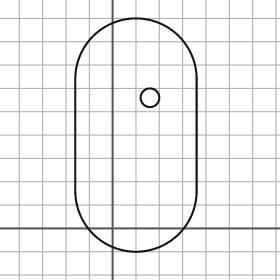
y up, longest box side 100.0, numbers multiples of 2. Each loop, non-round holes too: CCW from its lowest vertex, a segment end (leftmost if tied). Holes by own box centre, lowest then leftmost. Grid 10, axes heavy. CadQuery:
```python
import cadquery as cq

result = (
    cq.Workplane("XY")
    .moveTo(-16.0, 16.0)
    .threePointArc((10.0, -10.0), (36.0, 16.0))
    .lineTo(36.0, 64.0)
    .threePointArc((10.0, 90.0), (-16.0, 64.0))
    .close()
    .moveTo(16.0, 56.0)
    .circle(4.0)
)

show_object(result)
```